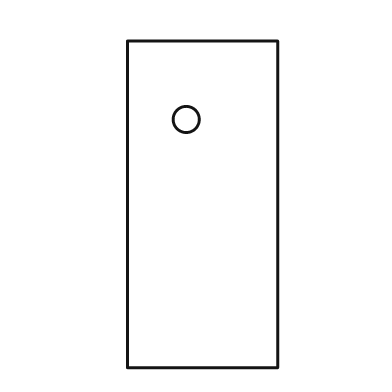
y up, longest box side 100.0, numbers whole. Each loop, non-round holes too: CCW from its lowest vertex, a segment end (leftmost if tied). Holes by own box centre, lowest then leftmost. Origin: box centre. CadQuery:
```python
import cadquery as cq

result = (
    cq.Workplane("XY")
    .moveTo(-23.0, -50.0)
    .lineTo(23.0, -50.0)
    .lineTo(23.0, 50.0)
    .lineTo(-23.0, 50.0)
    .close()
    .moveTo(-5.0, 26.0)
    .circle(4.0)
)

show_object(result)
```